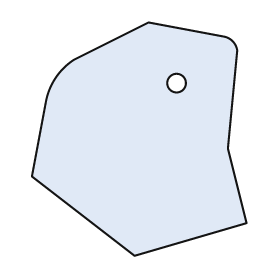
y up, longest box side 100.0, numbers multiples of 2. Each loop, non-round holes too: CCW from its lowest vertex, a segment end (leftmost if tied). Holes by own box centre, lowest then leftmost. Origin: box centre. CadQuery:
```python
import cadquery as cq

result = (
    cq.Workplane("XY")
    .moveTo(-2.0, -50.0)
    .lineTo(46.0, -36.0)
    .lineTo(38.0, -4.0)
    .lineTo(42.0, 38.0)
    .threePointArc((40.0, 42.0), (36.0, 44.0))
    .lineTo(4.0, 50.0)
    .lineTo(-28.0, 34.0)
    .threePointArc((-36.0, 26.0), (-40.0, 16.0))
    .lineTo(-46.0, -16.0)
    .close()
    .moveTo(16.0, 24.0)
    .circle(4.0)
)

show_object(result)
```